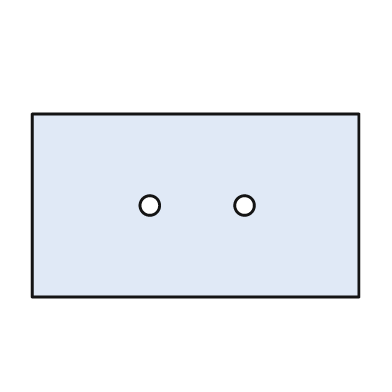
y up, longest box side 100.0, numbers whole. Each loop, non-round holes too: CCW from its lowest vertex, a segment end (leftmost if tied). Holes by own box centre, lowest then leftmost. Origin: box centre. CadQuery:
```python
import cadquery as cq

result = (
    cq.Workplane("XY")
    .moveTo(-50.0, -28.0)
    .lineTo(50.0, -28.0)
    .lineTo(50.0, 28.0)
    .lineTo(-50.0, 28.0)
    .close()
    .moveTo(-14.0, 0.0)
    .circle(3.0)
    .moveTo(15.0, 0.0)
    .circle(3.0)
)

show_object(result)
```